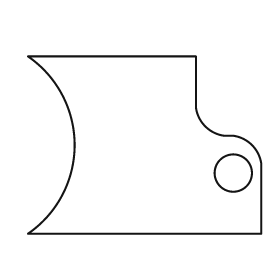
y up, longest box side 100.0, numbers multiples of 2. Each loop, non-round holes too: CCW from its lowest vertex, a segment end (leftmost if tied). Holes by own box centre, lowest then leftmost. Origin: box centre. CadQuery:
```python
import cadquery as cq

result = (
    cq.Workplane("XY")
    .moveTo(-50.0, -38.0)
    .lineTo(50.0, -38.0)
    .lineTo(50.0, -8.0)
    .threePointArc((46.0, 0.0), (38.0, 4.0))
    .lineTo(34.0, 4.0)
    .threePointArc((26.0, 8.0), (22.0, 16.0))
    .lineTo(22.0, 38.0)
    .lineTo(-50.0, 38.0)
    .threePointArc((-30.0, 0.0), (-50.0, -38.0))
    .close()
    .moveTo(38.0, -12.0)
    .circle(8.0)
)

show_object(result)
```